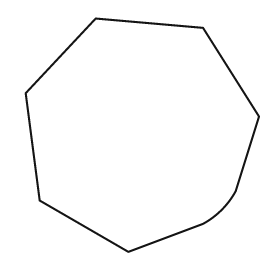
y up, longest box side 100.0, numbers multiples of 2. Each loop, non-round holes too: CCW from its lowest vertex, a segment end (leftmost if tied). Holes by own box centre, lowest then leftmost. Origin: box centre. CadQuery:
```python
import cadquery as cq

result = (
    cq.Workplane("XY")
    .moveTo(-6.0, -50.0)
    .lineTo(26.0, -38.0)
    .threePointArc((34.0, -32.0), (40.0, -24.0))
    .lineTo(50.0, 8.0)
    .lineTo(26.0, 46.0)
    .lineTo(-20.0, 50.0)
    .lineTo(-50.0, 18.0)
    .lineTo(-44.0, -28.0)
    .close()
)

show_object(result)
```